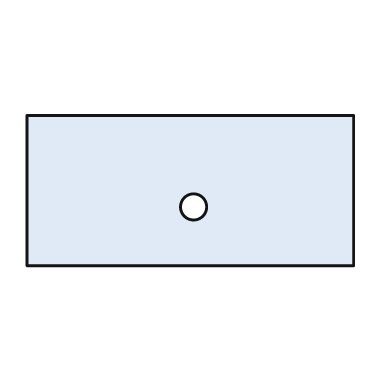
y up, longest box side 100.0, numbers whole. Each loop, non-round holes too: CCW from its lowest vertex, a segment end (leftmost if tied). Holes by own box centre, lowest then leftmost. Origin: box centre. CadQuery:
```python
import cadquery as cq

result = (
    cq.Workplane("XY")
    .moveTo(-50.0, -23.0)
    .lineTo(50.0, -23.0)
    .lineTo(50.0, 23.0)
    .lineTo(-50.0, 23.0)
    .close()
    .moveTo(1.0, -5.0)
    .circle(4.0)
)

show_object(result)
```